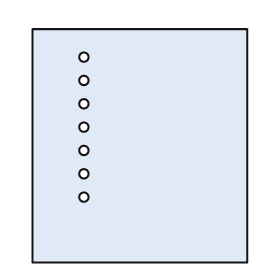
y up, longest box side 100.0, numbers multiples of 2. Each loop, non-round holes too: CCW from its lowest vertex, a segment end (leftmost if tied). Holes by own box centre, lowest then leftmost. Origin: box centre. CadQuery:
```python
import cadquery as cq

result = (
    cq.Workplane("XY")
    .moveTo(-46.0, -50.0)
    .lineTo(46.0, -50.0)
    .lineTo(46.0, 50.0)
    .lineTo(-46.0, 50.0)
    .close()
    .moveTo(-24.0, -22.0)
    .circle(2.0)
    .moveTo(-24.0, -12.0)
    .circle(2.0)
    .moveTo(-24.0, -2.0)
    .circle(2.0)
    .moveTo(-24.0, 8.0)
    .circle(2.0)
    .moveTo(-24.0, 18.0)
    .circle(2.0)
    .moveTo(-24.0, 28.0)
    .circle(2.0)
    .moveTo(-24.0, 38.0)
    .circle(2.0)
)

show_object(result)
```